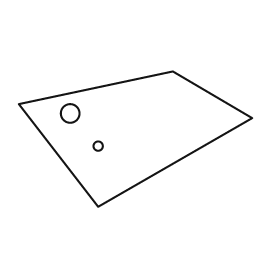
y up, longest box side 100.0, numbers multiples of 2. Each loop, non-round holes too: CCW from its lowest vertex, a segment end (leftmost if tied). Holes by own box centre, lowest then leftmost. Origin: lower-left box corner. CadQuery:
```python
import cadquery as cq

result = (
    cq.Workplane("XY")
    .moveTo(34.0, 0.0)
    .lineTo(100.0, 38.0)
    .lineTo(66.0, 58.0)
    .lineTo(0.0, 44.0)
    .close()
    .moveTo(34.0, 26.0)
    .circle(2.0)
    .moveTo(22.0, 40.0)
    .circle(4.0)
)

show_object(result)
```